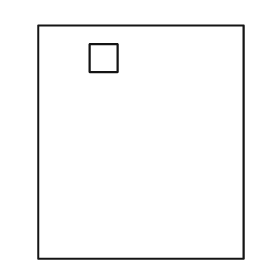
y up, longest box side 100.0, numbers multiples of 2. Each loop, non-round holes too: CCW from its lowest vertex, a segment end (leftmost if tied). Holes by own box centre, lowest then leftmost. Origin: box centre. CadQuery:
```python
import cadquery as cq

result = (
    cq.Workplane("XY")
    .moveTo(-44.0, -50.0)
    .lineTo(44.0, -50.0)
    .lineTo(44.0, 50.0)
    .lineTo(-44.0, 50.0)
    .close()
    .moveTo(-22.0, 30.0)
    .lineTo(-10.0, 30.0)
    .lineTo(-10.0, 42.0)
    .lineTo(-22.0, 42.0)
    .close()
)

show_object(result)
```